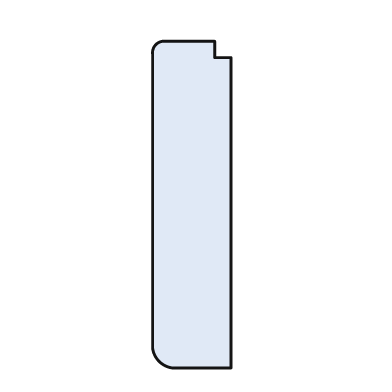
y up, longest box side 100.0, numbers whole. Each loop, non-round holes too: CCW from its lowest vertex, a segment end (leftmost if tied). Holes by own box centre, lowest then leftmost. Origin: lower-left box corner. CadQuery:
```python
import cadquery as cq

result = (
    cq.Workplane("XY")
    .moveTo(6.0, 0.0)
    .lineTo(24.0, 0.0)
    .lineTo(24.0, 95.0)
    .lineTo(19.0, 95.0)
    .lineTo(19.0, 100.0)
    .lineTo(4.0, 100.0)
    .threePointArc((1.0, 99.0), (0.0, 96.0))
    .lineTo(0.0, 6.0)
    .threePointArc((2.0, 2.0), (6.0, 0.0))
    .close()
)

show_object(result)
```